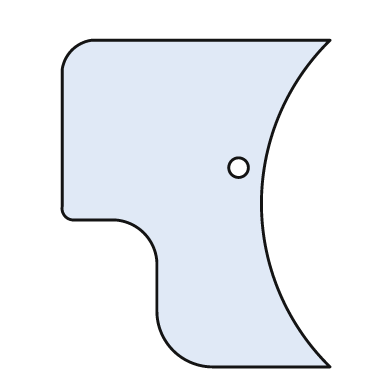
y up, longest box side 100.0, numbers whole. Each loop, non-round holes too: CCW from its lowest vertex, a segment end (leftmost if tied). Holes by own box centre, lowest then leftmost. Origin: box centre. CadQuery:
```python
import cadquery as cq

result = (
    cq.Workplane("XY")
    .moveTo(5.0, -50.0)
    .lineTo(41.0, -50.0)
    .threePointArc((20.0, 0.0), (41.0, 50.0))
    .lineTo(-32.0, 50.0)
    .threePointArc((-38.0, 47.0), (-41.0, 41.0))
    .lineTo(-41.0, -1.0)
    .threePointArc((-40.0, -4.0), (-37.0, -5.0))
    .lineTo(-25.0, -5.0)
    .threePointArc((-16.0, -9.0), (-12.0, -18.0))
    .lineTo(-12.0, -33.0)
    .threePointArc((-7.0, -45.0), (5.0, -50.0))
    .close()
    .moveTo(13.0, 11.0)
    .circle(3.0)
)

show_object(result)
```